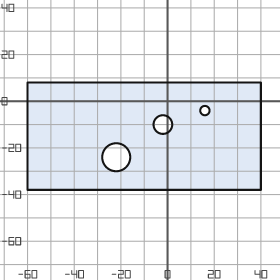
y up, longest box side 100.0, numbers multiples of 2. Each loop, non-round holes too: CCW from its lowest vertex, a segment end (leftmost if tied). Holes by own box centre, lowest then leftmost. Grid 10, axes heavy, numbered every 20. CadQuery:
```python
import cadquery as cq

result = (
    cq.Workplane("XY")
    .moveTo(-60.0, -38.0)
    .lineTo(40.0, -38.0)
    .lineTo(40.0, 8.0)
    .lineTo(-60.0, 8.0)
    .close()
    .moveTo(-22.0, -24.0)
    .circle(6.0)
    .moveTo(-2.0, -10.0)
    .circle(4.0)
    .moveTo(16.0, -4.0)
    .circle(2.0)
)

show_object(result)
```